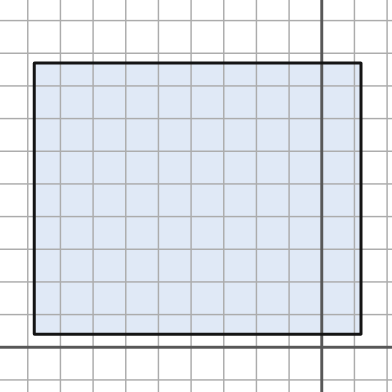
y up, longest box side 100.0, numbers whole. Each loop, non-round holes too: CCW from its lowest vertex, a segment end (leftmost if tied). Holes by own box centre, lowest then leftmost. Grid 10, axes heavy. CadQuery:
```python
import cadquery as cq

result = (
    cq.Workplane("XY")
    .moveTo(-88.0, 4.0)
    .lineTo(12.0, 4.0)
    .lineTo(12.0, 87.0)
    .lineTo(-88.0, 87.0)
    .close()
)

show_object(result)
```